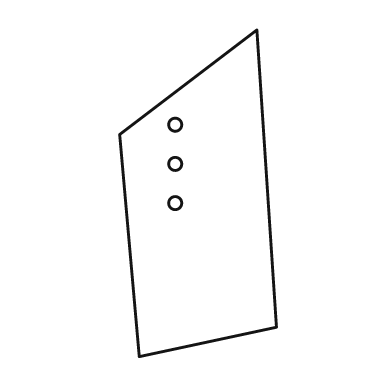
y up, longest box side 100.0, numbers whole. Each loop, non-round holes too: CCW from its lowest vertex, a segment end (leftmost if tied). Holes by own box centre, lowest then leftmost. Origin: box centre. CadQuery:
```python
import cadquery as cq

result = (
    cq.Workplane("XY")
    .moveTo(-18.0, -50.0)
    .lineTo(24.0, -41.0)
    .lineTo(18.0, 50.0)
    .lineTo(-24.0, 18.0)
    .close()
    .moveTo(-7.0, -3.0)
    .circle(2.0)
    .moveTo(-7.0, 9.0)
    .circle(2.0)
    .moveTo(-7.0, 21.0)
    .circle(2.0)
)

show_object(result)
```